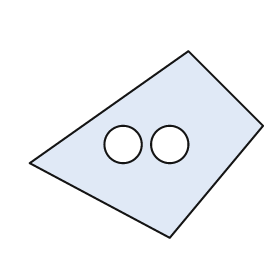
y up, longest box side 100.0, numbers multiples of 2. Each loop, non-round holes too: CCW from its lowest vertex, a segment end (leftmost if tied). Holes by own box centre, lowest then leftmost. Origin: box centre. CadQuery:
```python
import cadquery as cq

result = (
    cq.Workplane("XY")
    .moveTo(10.0, -40.0)
    .lineTo(50.0, 8.0)
    .lineTo(18.0, 40.0)
    .lineTo(-50.0, -8.0)
    .close()
    .moveTo(-10.0, 0.0)
    .circle(8.0)
    .moveTo(10.0, 0.0)
    .circle(8.0)
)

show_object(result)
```